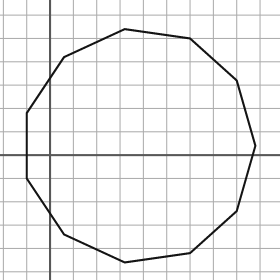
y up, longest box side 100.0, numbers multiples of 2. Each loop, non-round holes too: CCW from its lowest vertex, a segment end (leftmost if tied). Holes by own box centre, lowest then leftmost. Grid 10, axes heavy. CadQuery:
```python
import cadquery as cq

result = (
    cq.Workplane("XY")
    .moveTo(32.0, -46.0)
    .lineTo(60.0, -42.0)
    .lineTo(80.0, -24.0)
    .lineTo(88.0, 4.0)
    .lineTo(80.0, 32.0)
    .lineTo(60.0, 50.0)
    .lineTo(32.0, 54.0)
    .lineTo(6.0, 42.0)
    .lineTo(-10.0, 18.0)
    .lineTo(-10.0, -10.0)
    .lineTo(6.0, -34.0)
    .close()
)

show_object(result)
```